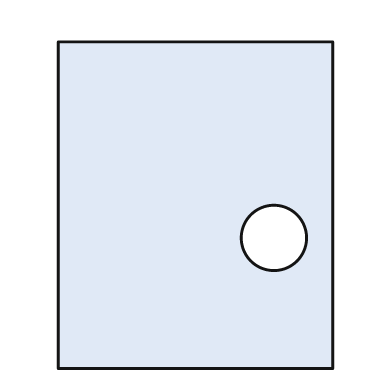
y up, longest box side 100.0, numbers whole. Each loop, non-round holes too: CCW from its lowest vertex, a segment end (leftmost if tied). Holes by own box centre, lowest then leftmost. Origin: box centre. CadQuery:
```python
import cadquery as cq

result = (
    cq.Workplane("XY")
    .moveTo(-42.0, -50.0)
    .lineTo(42.0, -50.0)
    .lineTo(42.0, 50.0)
    .lineTo(-42.0, 50.0)
    .close()
    .moveTo(24.0, -10.0)
    .circle(10.0)
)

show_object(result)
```